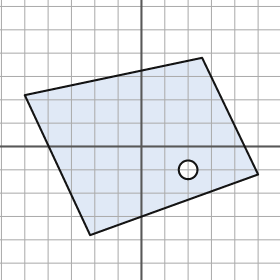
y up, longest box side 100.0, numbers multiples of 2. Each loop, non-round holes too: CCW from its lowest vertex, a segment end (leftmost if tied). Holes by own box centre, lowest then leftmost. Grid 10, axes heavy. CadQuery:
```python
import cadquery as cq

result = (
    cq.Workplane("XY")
    .moveTo(-22.0, -38.0)
    .lineTo(50.0, -12.0)
    .lineTo(26.0, 38.0)
    .lineTo(-50.0, 22.0)
    .close()
    .moveTo(20.0, -10.0)
    .circle(4.0)
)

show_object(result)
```